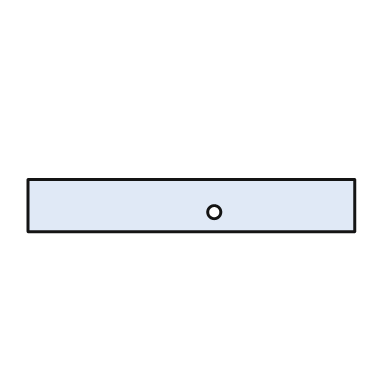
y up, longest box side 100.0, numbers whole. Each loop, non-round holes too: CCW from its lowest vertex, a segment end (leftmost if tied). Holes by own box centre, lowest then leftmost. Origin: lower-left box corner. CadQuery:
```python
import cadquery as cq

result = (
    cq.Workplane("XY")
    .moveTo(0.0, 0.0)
    .lineTo(100.0, 0.0)
    .lineTo(100.0, 16.0)
    .lineTo(0.0, 16.0)
    .close()
    .moveTo(57.0, 6.0)
    .circle(2.0)
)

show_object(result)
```